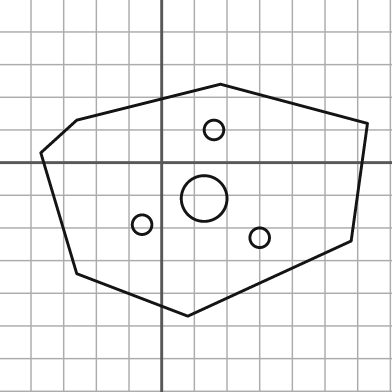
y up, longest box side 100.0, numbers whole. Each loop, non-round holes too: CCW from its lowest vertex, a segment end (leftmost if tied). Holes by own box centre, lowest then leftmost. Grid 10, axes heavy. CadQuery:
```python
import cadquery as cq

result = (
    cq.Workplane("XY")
    .moveTo(8.0, -47.0)
    .lineTo(58.0, -24.0)
    .lineTo(63.0, 12.0)
    .lineTo(18.0, 24.0)
    .lineTo(-26.0, 13.0)
    .lineTo(-37.0, 3.0)
    .lineTo(-26.0, -34.0)
    .close()
    .moveTo(30.0, -23.0)
    .circle(3.0)
    .moveTo(-6.0, -19.0)
    .circle(3.0)
    .moveTo(13.0, -11.0)
    .circle(7.0)
    .moveTo(16.0, 10.0)
    .circle(3.0)
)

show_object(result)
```